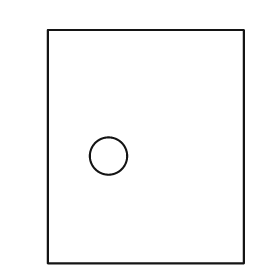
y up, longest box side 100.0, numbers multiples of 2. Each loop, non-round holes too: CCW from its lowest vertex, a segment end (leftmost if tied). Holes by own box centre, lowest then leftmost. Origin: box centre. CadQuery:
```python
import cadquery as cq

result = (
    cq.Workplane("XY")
    .moveTo(-42.0, -50.0)
    .lineTo(42.0, -50.0)
    .lineTo(42.0, 50.0)
    .lineTo(-42.0, 50.0)
    .close()
    .moveTo(-16.0, -4.0)
    .circle(8.0)
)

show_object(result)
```